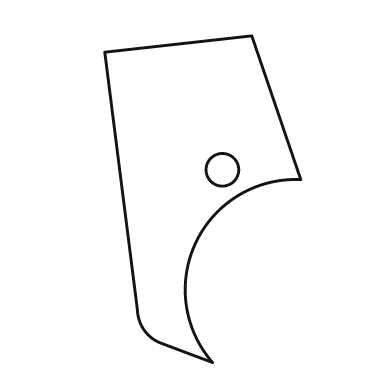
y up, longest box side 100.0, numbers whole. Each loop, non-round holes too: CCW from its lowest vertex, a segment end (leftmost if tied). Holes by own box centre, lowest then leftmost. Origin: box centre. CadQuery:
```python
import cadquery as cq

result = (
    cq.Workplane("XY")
    .moveTo(3.0, -50.0)
    .threePointArc((-2.0, -13.0), (30.0, 6.0))
    .lineTo(15.0, 50.0)
    .lineTo(-30.0, 45.0)
    .lineTo(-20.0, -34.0)
    .threePointArc((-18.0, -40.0), (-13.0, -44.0))
    .close()
    .moveTo(6.0, 9.0)
    .circle(5.0)
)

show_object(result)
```